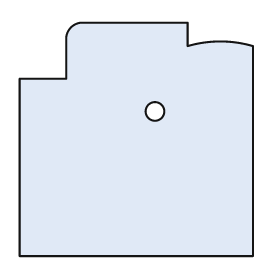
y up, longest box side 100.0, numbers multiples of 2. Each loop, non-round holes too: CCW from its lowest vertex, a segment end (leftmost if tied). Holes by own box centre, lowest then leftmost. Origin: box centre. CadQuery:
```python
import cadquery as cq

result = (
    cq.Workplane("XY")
    .moveTo(-50.0, -50.0)
    .lineTo(50.0, -50.0)
    .lineTo(50.0, 40.0)
    .threePointArc((36.0, 42.0), (22.0, 40.0))
    .lineTo(22.0, 50.0)
    .lineTo(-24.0, 50.0)
    .threePointArc((-28.0, 48.0), (-30.0, 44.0))
    .lineTo(-30.0, 26.0)
    .lineTo(-50.0, 26.0)
    .close()
    .moveTo(8.0, 12.0)
    .circle(4.0)
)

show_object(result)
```